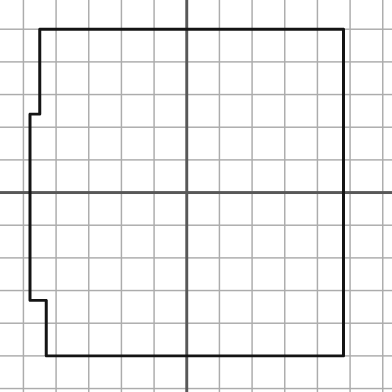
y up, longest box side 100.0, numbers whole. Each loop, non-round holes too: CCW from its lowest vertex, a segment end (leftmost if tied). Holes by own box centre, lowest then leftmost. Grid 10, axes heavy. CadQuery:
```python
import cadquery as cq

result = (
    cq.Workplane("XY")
    .moveTo(-43.0, -50.0)
    .lineTo(48.0, -50.0)
    .lineTo(48.0, 50.0)
    .lineTo(-45.0, 50.0)
    .lineTo(-45.0, 24.0)
    .lineTo(-48.0, 24.0)
    .lineTo(-48.0, -33.0)
    .lineTo(-43.0, -33.0)
    .close()
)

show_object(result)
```